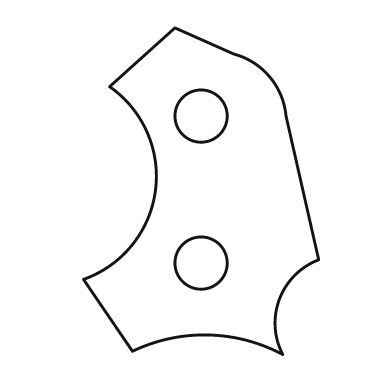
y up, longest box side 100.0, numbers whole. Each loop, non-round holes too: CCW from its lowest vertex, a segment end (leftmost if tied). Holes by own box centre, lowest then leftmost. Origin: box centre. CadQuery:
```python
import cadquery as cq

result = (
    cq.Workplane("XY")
    .moveTo(25.0, -50.0)
    .threePointArc((24.0, -33.0), (36.0, -21.0))
    .lineTo(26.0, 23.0)
    .threePointArc((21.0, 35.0), (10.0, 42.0))
    .lineTo(-8.0, 50.0)
    .lineTo(-28.0, 32.0)
    .threePointArc((-14.0, 0.0), (-36.0, -27.0))
    .lineTo(-21.0, -49.0)
    .threePointArc((2.0, -44.0), (25.0, -50.0))
    .close()
    .moveTo(0.0, -22.0)
    .circle(8.0)
    .moveTo(0.0, 23.0)
    .circle(8.0)
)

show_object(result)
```